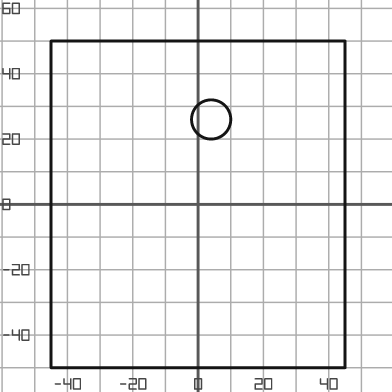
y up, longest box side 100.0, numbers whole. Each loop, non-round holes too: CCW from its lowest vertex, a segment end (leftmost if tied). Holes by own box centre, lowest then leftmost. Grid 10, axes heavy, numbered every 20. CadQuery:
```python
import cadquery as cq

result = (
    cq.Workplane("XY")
    .moveTo(-45.0, -50.0)
    .lineTo(45.0, -50.0)
    .lineTo(45.0, 50.0)
    .lineTo(-45.0, 50.0)
    .close()
    .moveTo(4.0, 26.0)
    .circle(6.0)
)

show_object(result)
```